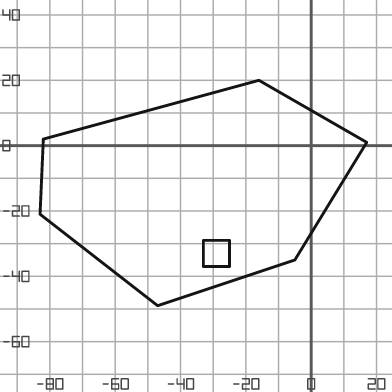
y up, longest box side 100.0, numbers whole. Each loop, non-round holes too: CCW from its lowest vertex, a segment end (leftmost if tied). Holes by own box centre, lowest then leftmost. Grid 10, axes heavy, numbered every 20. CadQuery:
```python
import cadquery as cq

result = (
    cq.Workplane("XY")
    .moveTo(-47.0, -49.0)
    .lineTo(-5.0, -35.0)
    .lineTo(17.0, 1.0)
    .lineTo(-16.0, 20.0)
    .lineTo(-82.0, 2.0)
    .lineTo(-83.0, -21.0)
    .close()
    .moveTo(-33.0, -37.0)
    .lineTo(-25.0, -37.0)
    .lineTo(-25.0, -29.0)
    .lineTo(-33.0, -29.0)
    .close()
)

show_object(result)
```